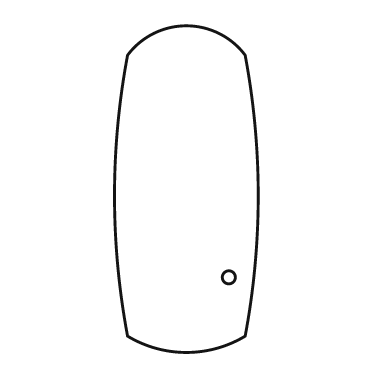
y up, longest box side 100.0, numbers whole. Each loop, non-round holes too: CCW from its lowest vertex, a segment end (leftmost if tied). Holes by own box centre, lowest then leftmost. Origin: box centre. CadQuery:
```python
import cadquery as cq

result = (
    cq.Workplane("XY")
    .moveTo(-18.0, -45.0)
    .threePointArc((0.0, -50.0), (18.0, -45.0))
    .threePointArc((22.0, -2.0), (18.0, 41.0))
    .threePointArc((0.0, 50.0), (-18.0, 41.0))
    .threePointArc((-22.0, -2.0), (-18.0, -45.0))
    .close()
    .moveTo(13.0, -27.0)
    .circle(2.0)
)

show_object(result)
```